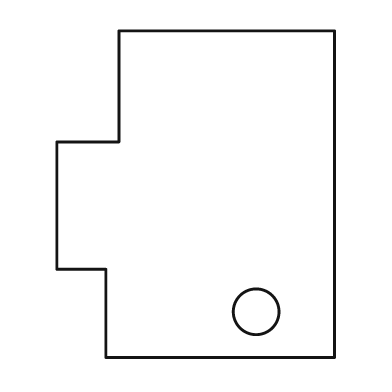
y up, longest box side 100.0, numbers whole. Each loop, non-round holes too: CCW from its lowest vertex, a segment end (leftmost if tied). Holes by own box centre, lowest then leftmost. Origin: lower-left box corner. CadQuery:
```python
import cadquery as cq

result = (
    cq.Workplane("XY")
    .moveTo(15.0, 0.0)
    .lineTo(85.0, 0.0)
    .lineTo(85.0, 100.0)
    .lineTo(19.0, 100.0)
    .lineTo(19.0, 66.0)
    .lineTo(0.0, 66.0)
    .lineTo(0.0, 27.0)
    .lineTo(15.0, 27.0)
    .close()
    .moveTo(61.0, 14.0)
    .circle(7.0)
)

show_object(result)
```